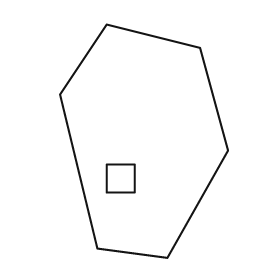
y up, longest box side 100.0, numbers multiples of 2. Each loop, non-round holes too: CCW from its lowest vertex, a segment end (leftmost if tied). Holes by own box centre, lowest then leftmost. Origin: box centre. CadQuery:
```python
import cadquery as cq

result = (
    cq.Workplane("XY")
    .moveTo(10.0, -50.0)
    .lineTo(36.0, -4.0)
    .lineTo(24.0, 40.0)
    .lineTo(-16.0, 50.0)
    .lineTo(-36.0, 20.0)
    .lineTo(-20.0, -46.0)
    .close()
    .moveTo(-16.0, -22.0)
    .lineTo(-4.0, -22.0)
    .lineTo(-4.0, -10.0)
    .lineTo(-16.0, -10.0)
    .close()
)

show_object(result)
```